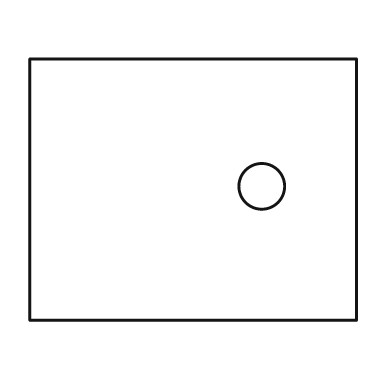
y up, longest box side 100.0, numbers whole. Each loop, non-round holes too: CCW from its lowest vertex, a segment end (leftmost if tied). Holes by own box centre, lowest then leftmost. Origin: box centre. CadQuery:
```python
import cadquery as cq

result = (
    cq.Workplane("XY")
    .moveTo(-50.0, -40.0)
    .lineTo(50.0, -40.0)
    .lineTo(50.0, 40.0)
    .lineTo(-50.0, 40.0)
    .close()
    .moveTo(21.0, 1.0)
    .circle(7.0)
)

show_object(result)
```